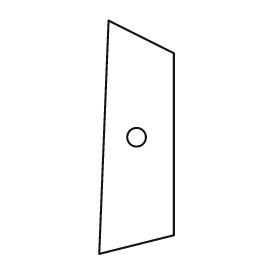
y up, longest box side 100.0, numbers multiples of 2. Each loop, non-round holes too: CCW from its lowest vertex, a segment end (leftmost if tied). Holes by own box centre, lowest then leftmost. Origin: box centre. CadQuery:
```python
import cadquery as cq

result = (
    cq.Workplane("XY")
    .moveTo(-16.0, -50.0)
    .lineTo(16.0, -42.0)
    .lineTo(16.0, 36.0)
    .lineTo(-12.0, 50.0)
    .close()
    .moveTo(0.0, 0.0)
    .circle(4.0)
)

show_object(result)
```